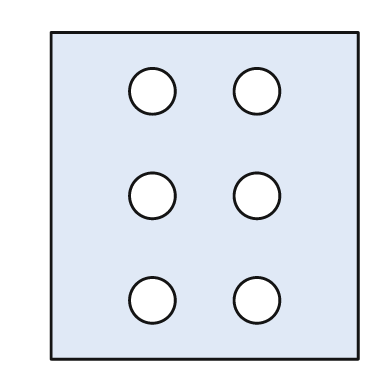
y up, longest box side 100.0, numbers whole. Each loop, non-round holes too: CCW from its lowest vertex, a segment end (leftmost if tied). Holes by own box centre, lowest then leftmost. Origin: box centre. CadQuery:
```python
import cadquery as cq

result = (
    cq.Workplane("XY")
    .moveTo(-47.0, -50.0)
    .lineTo(47.0, -50.0)
    .lineTo(47.0, 50.0)
    .lineTo(-47.0, 50.0)
    .close()
    .moveTo(-16.0, -32.0)
    .circle(7.0)
    .moveTo(16.0, -32.0)
    .circle(7.0)
    .moveTo(-16.0, 0.0)
    .circle(7.0)
    .moveTo(16.0, 0.0)
    .circle(7.0)
    .moveTo(-16.0, 32.0)
    .circle(7.0)
    .moveTo(16.0, 32.0)
    .circle(7.0)
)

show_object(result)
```